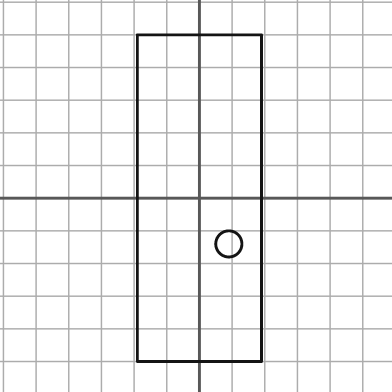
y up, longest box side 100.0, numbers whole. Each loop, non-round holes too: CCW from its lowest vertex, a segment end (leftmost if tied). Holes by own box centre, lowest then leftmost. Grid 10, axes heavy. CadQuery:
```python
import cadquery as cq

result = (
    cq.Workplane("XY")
    .moveTo(-19.0, -50.0)
    .lineTo(19.0, -50.0)
    .lineTo(19.0, 50.0)
    .lineTo(-19.0, 50.0)
    .close()
    .moveTo(9.0, -14.0)
    .circle(4.0)
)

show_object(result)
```